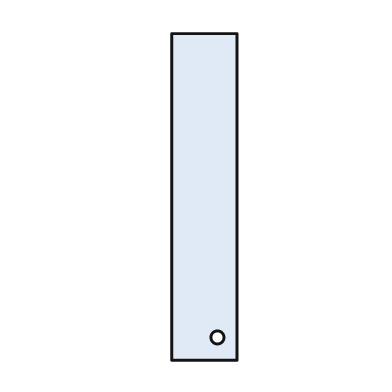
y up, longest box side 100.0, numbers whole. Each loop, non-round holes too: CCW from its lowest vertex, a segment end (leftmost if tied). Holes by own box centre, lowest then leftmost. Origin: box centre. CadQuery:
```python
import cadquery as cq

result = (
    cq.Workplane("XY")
    .moveTo(-10.0, -50.0)
    .lineTo(10.0, -50.0)
    .lineTo(10.0, 50.0)
    .lineTo(-10.0, 50.0)
    .close()
    .moveTo(4.0, -43.0)
    .circle(2.0)
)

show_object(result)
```